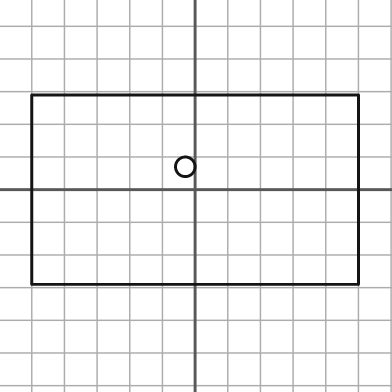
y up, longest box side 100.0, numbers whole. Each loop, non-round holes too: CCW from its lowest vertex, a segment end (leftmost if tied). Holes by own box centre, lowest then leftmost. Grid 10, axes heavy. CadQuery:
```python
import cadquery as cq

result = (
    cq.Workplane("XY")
    .moveTo(-50.0, -29.0)
    .lineTo(50.0, -29.0)
    .lineTo(50.0, 29.0)
    .lineTo(-50.0, 29.0)
    .close()
    .moveTo(-3.0, 7.0)
    .circle(3.0)
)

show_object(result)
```